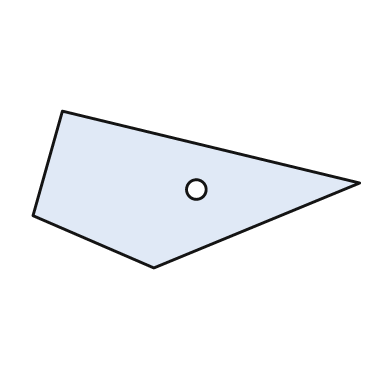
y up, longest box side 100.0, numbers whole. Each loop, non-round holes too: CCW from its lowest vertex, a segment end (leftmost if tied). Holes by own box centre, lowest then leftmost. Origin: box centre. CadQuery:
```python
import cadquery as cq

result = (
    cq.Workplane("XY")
    .moveTo(-13.0, -24.0)
    .lineTo(50.0, 2.0)
    .lineTo(-41.0, 24.0)
    .lineTo(-50.0, -8.0)
    .close()
    .moveTo(0.0, 0.0)
    .circle(3.0)
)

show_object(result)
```